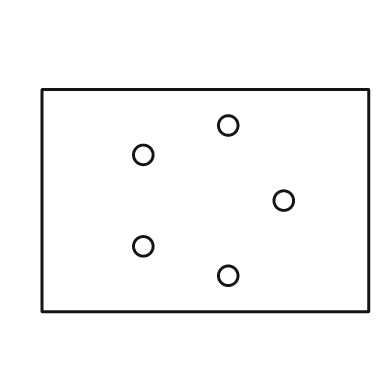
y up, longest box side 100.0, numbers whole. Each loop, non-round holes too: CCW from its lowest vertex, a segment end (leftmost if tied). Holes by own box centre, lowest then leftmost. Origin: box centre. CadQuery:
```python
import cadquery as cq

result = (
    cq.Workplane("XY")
    .moveTo(-50.0, -34.0)
    .lineTo(50.0, -34.0)
    .lineTo(50.0, 34.0)
    .lineTo(-50.0, 34.0)
    .close()
    .moveTo(7.0, -23.0)
    .circle(3.0)
    .moveTo(-19.0, -14.0)
    .circle(3.0)
    .moveTo(24.0, 0.0)
    .circle(3.0)
    .moveTo(-19.0, 14.0)
    .circle(3.0)
    .moveTo(7.0, 23.0)
    .circle(3.0)
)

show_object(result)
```